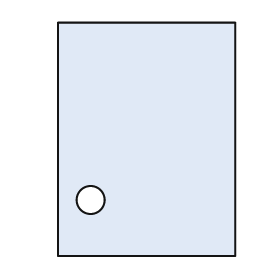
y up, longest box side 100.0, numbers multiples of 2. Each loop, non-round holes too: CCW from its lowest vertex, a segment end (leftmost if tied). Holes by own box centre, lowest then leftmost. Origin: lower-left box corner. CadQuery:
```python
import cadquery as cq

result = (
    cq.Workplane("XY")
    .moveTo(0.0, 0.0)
    .lineTo(76.0, 0.0)
    .lineTo(76.0, 100.0)
    .lineTo(0.0, 100.0)
    .close()
    .moveTo(14.0, 24.0)
    .circle(6.0)
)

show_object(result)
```